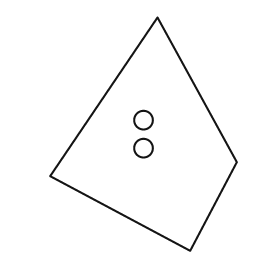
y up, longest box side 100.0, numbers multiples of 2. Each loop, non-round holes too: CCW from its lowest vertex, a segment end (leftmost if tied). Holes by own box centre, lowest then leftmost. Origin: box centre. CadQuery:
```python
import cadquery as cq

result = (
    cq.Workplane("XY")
    .moveTo(20.0, -50.0)
    .lineTo(40.0, -12.0)
    .lineTo(6.0, 50.0)
    .lineTo(-40.0, -18.0)
    .close()
    .moveTo(0.0, -6.0)
    .circle(4.0)
    .moveTo(0.0, 6.0)
    .circle(4.0)
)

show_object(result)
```